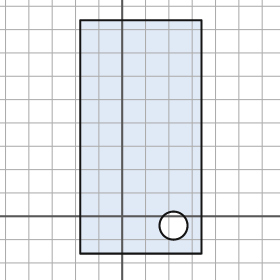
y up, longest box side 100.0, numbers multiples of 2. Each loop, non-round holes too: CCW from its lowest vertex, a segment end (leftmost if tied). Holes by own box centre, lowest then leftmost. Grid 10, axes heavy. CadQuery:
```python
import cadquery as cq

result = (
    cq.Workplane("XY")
    .moveTo(-18.0, -16.0)
    .lineTo(34.0, -16.0)
    .lineTo(34.0, 84.0)
    .lineTo(-18.0, 84.0)
    .close()
    .moveTo(22.0, -4.0)
    .circle(6.0)
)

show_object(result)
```